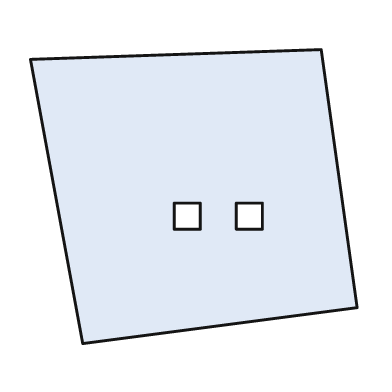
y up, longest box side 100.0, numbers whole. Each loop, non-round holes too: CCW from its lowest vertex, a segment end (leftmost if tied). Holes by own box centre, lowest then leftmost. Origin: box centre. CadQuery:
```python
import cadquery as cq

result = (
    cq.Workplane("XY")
    .moveTo(-34.0, -45.0)
    .lineTo(50.0, -34.0)
    .lineTo(39.0, 45.0)
    .lineTo(-50.0, 42.0)
    .close()
    .moveTo(-6.0, -10.0)
    .lineTo(2.0, -10.0)
    .lineTo(2.0, -2.0)
    .lineTo(-6.0, -2.0)
    .close()
    .moveTo(13.0, -10.0)
    .lineTo(21.0, -10.0)
    .lineTo(21.0, -2.0)
    .lineTo(13.0, -2.0)
    .close()
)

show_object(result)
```